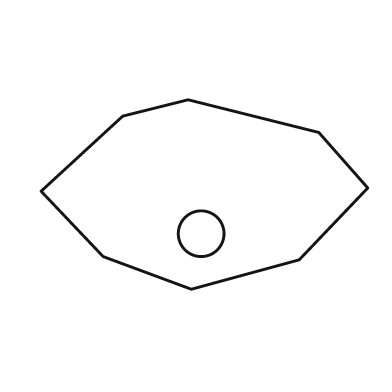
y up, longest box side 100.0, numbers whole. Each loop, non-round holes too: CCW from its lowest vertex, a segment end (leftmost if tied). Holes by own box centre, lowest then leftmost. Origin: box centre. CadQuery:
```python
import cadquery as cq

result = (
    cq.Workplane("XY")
    .moveTo(-4.0, -29.0)
    .lineTo(29.0, -20.0)
    .lineTo(50.0, 2.0)
    .lineTo(35.0, 19.0)
    .lineTo(-5.0, 29.0)
    .lineTo(-25.0, 24.0)
    .lineTo(-50.0, 1.0)
    .lineTo(-31.0, -19.0)
    .close()
    .moveTo(-1.0, -12.0)
    .circle(7.0)
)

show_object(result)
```